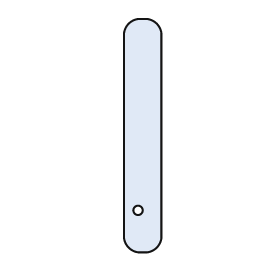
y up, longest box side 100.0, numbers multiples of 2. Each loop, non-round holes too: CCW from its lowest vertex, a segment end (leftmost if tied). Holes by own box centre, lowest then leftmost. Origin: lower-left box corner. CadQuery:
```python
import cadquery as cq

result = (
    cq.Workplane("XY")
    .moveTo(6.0, 0.0)
    .lineTo(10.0, 0.0)
    .threePointArc((14.0, 2.0), (16.0, 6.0))
    .lineTo(16.0, 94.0)
    .threePointArc((14.0, 98.0), (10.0, 100.0))
    .lineTo(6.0, 100.0)
    .threePointArc((2.0, 98.0), (0.0, 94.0))
    .lineTo(0.0, 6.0)
    .threePointArc((2.0, 2.0), (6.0, 0.0))
    .close()
    .moveTo(6.0, 18.0)
    .circle(2.0)
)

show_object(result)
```